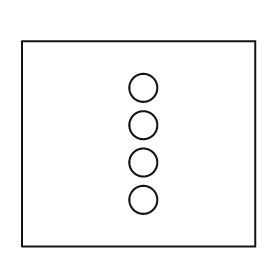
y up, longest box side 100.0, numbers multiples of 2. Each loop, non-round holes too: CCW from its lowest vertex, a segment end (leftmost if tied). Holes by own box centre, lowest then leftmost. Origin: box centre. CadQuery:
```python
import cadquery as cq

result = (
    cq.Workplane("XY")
    .moveTo(-50.0, -44.0)
    .lineTo(50.0, -44.0)
    .lineTo(50.0, 44.0)
    .lineTo(-50.0, 44.0)
    .close()
    .moveTo(2.0, -24.0)
    .circle(6.0)
    .moveTo(2.0, -8.0)
    .circle(6.0)
    .moveTo(2.0, 8.0)
    .circle(6.0)
    .moveTo(2.0, 24.0)
    .circle(6.0)
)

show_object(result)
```